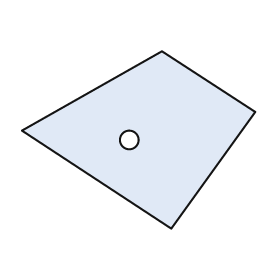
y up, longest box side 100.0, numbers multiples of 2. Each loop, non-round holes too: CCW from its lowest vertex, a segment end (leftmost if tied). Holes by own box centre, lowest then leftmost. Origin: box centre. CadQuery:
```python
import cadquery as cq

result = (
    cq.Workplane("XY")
    .moveTo(14.0, -38.0)
    .lineTo(50.0, 12.0)
    .lineTo(10.0, 38.0)
    .lineTo(-50.0, 4.0)
    .close()
    .moveTo(-4.0, 0.0)
    .circle(4.0)
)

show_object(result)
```